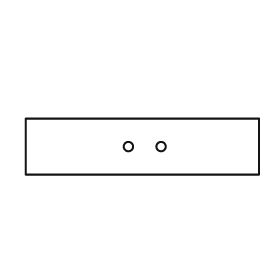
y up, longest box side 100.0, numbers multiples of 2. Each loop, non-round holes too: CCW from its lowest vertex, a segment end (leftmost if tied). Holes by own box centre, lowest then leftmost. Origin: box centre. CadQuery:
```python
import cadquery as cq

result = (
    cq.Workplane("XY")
    .moveTo(-50.0, -12.0)
    .lineTo(50.0, -12.0)
    .lineTo(50.0, 12.0)
    .lineTo(-50.0, 12.0)
    .close()
    .moveTo(-6.0, 0.0)
    .circle(2.0)
    .moveTo(8.0, 0.0)
    .circle(2.0)
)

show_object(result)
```